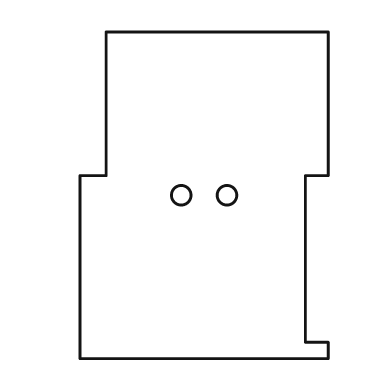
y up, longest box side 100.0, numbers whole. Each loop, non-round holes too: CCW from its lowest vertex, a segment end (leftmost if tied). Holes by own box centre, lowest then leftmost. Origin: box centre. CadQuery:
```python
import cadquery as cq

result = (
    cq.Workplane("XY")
    .moveTo(-38.0, -50.0)
    .lineTo(38.0, -50.0)
    .lineTo(38.0, -45.0)
    .lineTo(31.0, -45.0)
    .lineTo(31.0, 6.0)
    .lineTo(38.0, 6.0)
    .lineTo(38.0, 50.0)
    .lineTo(-30.0, 50.0)
    .lineTo(-30.0, 6.0)
    .lineTo(-38.0, 6.0)
    .close()
    .moveTo(-7.0, 0.0)
    .circle(3.0)
    .moveTo(7.0, 0.0)
    .circle(3.0)
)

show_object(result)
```